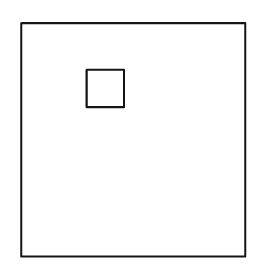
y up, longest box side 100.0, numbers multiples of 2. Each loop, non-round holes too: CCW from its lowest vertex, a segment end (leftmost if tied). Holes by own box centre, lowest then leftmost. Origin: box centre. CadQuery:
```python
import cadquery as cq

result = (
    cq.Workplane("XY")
    .moveTo(-48.0, -50.0)
    .lineTo(48.0, -50.0)
    .lineTo(48.0, 50.0)
    .lineTo(-48.0, 50.0)
    .close()
    .moveTo(-20.0, 14.0)
    .lineTo(-4.0, 14.0)
    .lineTo(-4.0, 30.0)
    .lineTo(-20.0, 30.0)
    .close()
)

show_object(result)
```